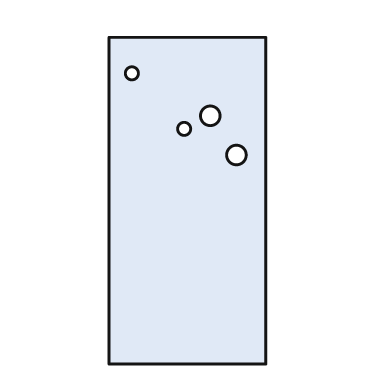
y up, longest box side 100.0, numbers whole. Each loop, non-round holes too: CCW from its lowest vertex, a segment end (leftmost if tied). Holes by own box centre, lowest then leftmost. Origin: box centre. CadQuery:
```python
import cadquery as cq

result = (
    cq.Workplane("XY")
    .moveTo(-24.0, -50.0)
    .lineTo(24.0, -50.0)
    .lineTo(24.0, 50.0)
    .lineTo(-24.0, 50.0)
    .close()
    .moveTo(15.0, 14.0)
    .circle(3.0)
    .moveTo(-1.0, 22.0)
    .circle(2.0)
    .moveTo(7.0, 26.0)
    .circle(3.0)
    .moveTo(-17.0, 39.0)
    .circle(2.0)
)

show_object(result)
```